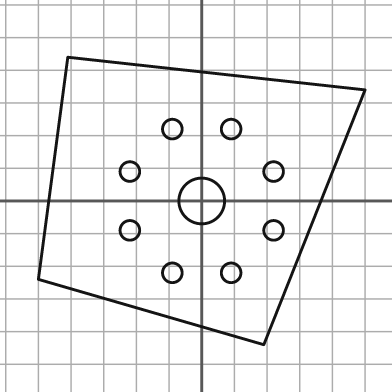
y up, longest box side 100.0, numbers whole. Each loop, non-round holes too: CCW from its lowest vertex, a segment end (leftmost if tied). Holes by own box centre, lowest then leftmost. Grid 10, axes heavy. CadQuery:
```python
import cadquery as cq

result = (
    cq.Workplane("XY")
    .moveTo(19.0, -44.0)
    .lineTo(50.0, 34.0)
    .lineTo(-41.0, 44.0)
    .lineTo(-50.0, -24.0)
    .close()
    .moveTo(-9.0, -22.0)
    .circle(3.0)
    .moveTo(9.0, -22.0)
    .circle(3.0)
    .moveTo(-22.0, -9.0)
    .circle(3.0)
    .moveTo(22.0, -9.0)
    .circle(3.0)
    .moveTo(0.0, 0.0)
    .circle(7.0)
    .moveTo(-22.0, 9.0)
    .circle(3.0)
    .moveTo(22.0, 9.0)
    .circle(3.0)
    .moveTo(-9.0, 22.0)
    .circle(3.0)
    .moveTo(9.0, 22.0)
    .circle(3.0)
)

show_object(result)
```